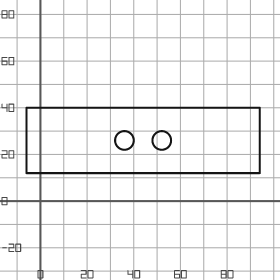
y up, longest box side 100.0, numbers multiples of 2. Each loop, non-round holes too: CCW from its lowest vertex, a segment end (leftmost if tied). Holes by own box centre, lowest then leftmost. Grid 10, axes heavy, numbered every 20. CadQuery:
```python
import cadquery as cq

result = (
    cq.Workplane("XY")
    .moveTo(-6.0, 12.0)
    .lineTo(94.0, 12.0)
    .lineTo(94.0, 40.0)
    .lineTo(-6.0, 40.0)
    .close()
    .moveTo(36.0, 26.0)
    .circle(4.0)
    .moveTo(52.0, 26.0)
    .circle(4.0)
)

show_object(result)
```